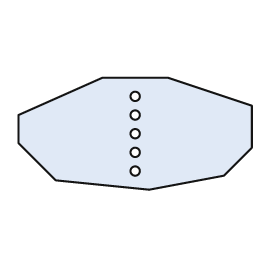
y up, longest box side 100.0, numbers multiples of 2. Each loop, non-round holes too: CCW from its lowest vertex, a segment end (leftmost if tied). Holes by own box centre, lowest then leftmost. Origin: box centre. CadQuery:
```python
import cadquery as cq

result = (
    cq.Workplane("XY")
    .moveTo(6.0, -24.0)
    .lineTo(38.0, -18.0)
    .lineTo(50.0, -6.0)
    .lineTo(50.0, 12.0)
    .lineTo(14.0, 24.0)
    .lineTo(-14.0, 24.0)
    .lineTo(-50.0, 8.0)
    .lineTo(-50.0, -4.0)
    .lineTo(-34.0, -20.0)
    .close()
    .moveTo(0.0, -16.0)
    .circle(2.0)
    .moveTo(0.0, -8.0)
    .circle(2.0)
    .moveTo(0.0, 0.0)
    .circle(2.0)
    .moveTo(0.0, 8.0)
    .circle(2.0)
    .moveTo(0.0, 16.0)
    .circle(2.0)
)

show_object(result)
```